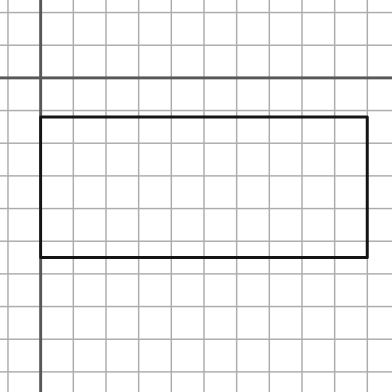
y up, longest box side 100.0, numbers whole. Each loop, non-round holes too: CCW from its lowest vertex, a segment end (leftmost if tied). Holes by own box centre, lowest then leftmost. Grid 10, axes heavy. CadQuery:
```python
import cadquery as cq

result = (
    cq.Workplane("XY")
    .moveTo(0.0, -55.0)
    .lineTo(100.0, -55.0)
    .lineTo(100.0, -12.0)
    .lineTo(0.0, -12.0)
    .close()
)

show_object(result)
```